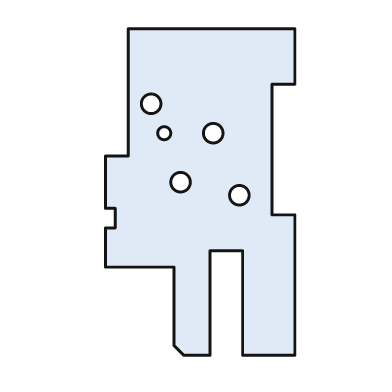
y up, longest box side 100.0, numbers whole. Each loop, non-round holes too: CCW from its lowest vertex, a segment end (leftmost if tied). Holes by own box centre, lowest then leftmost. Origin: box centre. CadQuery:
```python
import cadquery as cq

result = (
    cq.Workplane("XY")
    .moveTo(-5.0, -50.0)
    .lineTo(3.0, -50.0)
    .lineTo(3.0, -18.0)
    .lineTo(13.0, -18.0)
    .lineTo(13.0, -50.0)
    .lineTo(29.0, -50.0)
    .lineTo(29.0, -7.0)
    .lineTo(22.0, -7.0)
    .lineTo(22.0, 33.0)
    .lineTo(29.0, 33.0)
    .lineTo(29.0, 50.0)
    .lineTo(-22.0, 50.0)
    .lineTo(-22.0, 11.0)
    .lineTo(-29.0, 11.0)
    .lineTo(-29.0, -5.0)
    .lineTo(-26.0, -5.0)
    .lineTo(-26.0, -11.0)
    .lineTo(-29.0, -11.0)
    .lineTo(-29.0, -23.0)
    .lineTo(-8.0, -23.0)
    .lineTo(-8.0, -47.0)
    .close()
    .moveTo(12.0, -1.0)
    .circle(3.0)
    .moveTo(-6.0, 3.0)
    .circle(3.0)
    .moveTo(-11.0, 18.0)
    .circle(2.0)
    .moveTo(4.0, 18.0)
    .circle(3.0)
    .moveTo(-15.0, 27.0)
    .circle(3.0)
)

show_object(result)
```